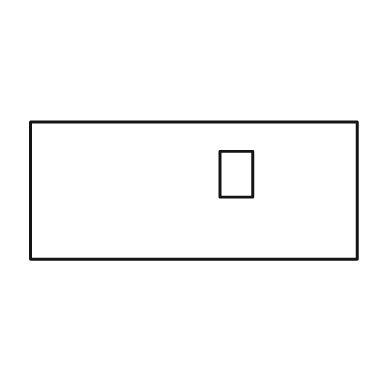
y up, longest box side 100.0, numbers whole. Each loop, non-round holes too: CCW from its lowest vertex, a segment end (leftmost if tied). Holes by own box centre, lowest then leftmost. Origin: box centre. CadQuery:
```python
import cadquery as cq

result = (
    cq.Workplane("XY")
    .moveTo(-50.0, -21.0)
    .lineTo(50.0, -21.0)
    .lineTo(50.0, 21.0)
    .lineTo(-50.0, 21.0)
    .close()
    .moveTo(8.0, -2.0)
    .lineTo(18.0, -2.0)
    .lineTo(18.0, 12.0)
    .lineTo(8.0, 12.0)
    .close()
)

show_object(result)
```